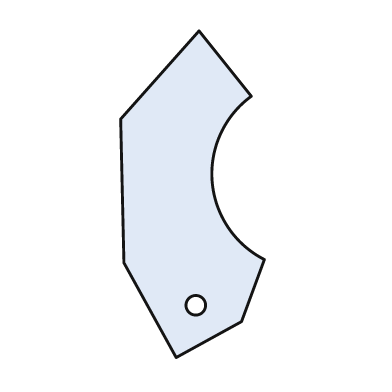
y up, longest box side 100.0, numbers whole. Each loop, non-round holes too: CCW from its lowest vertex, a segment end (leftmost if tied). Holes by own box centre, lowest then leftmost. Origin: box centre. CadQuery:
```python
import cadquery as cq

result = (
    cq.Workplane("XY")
    .moveTo(-5.0, -50.0)
    .lineTo(15.0, -39.0)
    .lineTo(22.0, -20.0)
    .threePointArc((6.0, 4.0), (18.0, 30.0))
    .lineTo(2.0, 50.0)
    .lineTo(-22.0, 23.0)
    .lineTo(-21.0, -21.0)
    .close()
    .moveTo(1.0, -34.0)
    .circle(3.0)
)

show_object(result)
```